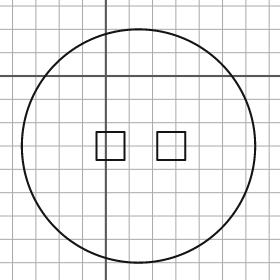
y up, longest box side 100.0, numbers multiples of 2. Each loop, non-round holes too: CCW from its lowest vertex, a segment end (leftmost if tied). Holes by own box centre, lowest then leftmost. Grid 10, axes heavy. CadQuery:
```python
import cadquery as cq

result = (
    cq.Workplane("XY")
    .moveTo(14.0, -30.0)
    .circle(50.0)
    .moveTo(-4.0, -36.0)
    .lineTo(8.0, -36.0)
    .lineTo(8.0, -24.0)
    .lineTo(-4.0, -24.0)
    .close()
    .moveTo(22.0, -36.0)
    .lineTo(34.0, -36.0)
    .lineTo(34.0, -24.0)
    .lineTo(22.0, -24.0)
    .close()
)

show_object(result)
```